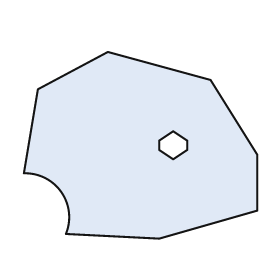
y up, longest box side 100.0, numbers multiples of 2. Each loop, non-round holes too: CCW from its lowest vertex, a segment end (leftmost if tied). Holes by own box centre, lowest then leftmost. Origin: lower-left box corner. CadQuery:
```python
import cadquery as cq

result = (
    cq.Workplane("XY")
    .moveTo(58.0, 0.0)
    .lineTo(100.0, 12.0)
    .lineTo(100.0, 36.0)
    .lineTo(80.0, 68.0)
    .lineTo(36.0, 80.0)
    .lineTo(6.0, 64.0)
    .lineTo(0.0, 28.0)
    .threePointArc((16.0, 20.0), (18.0, 2.0))
    .close()
    .moveTo(64.0, 34.0)
    .lineTo(70.0, 38.0)
    .lineTo(70.0, 42.0)
    .lineTo(64.0, 46.0)
    .lineTo(58.0, 42.0)
    .lineTo(58.0, 38.0)
    .close()
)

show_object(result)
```